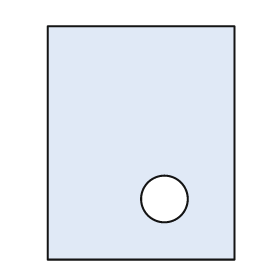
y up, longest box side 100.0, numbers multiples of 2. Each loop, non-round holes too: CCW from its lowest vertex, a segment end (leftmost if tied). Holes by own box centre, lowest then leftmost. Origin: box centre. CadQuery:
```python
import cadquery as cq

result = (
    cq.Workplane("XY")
    .moveTo(-40.0, -50.0)
    .lineTo(40.0, -50.0)
    .lineTo(40.0, 50.0)
    .lineTo(-40.0, 50.0)
    .close()
    .moveTo(10.0, -24.0)
    .circle(10.0)
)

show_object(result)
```